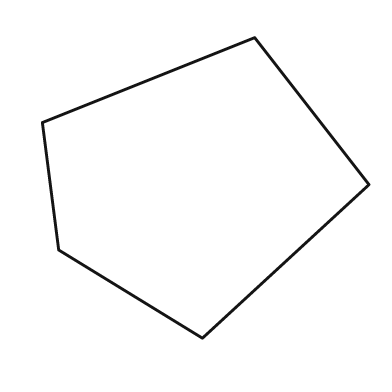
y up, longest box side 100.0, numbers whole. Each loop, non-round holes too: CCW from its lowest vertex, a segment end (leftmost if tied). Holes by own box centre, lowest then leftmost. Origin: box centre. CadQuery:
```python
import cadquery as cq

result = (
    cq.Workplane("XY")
    .moveTo(-1.0, -46.0)
    .lineTo(50.0, 1.0)
    .lineTo(15.0, 46.0)
    .lineTo(-50.0, 20.0)
    .lineTo(-45.0, -19.0)
    .close()
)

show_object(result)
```